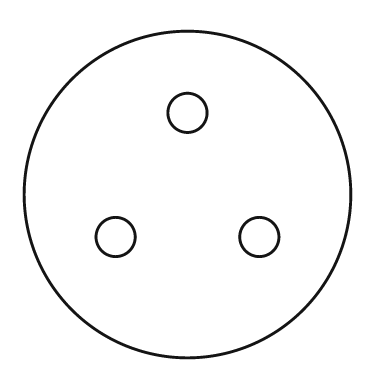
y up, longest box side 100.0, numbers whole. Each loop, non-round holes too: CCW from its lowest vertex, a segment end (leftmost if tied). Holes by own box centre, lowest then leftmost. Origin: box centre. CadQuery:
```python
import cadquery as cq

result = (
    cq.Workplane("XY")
    .moveTo(0.0, 0.0)
    .circle(50.0)
    .moveTo(-22.0, -13.0)
    .circle(6.0)
    .moveTo(22.0, -13.0)
    .circle(6.0)
    .moveTo(0.0, 25.0)
    .circle(6.0)
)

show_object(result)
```